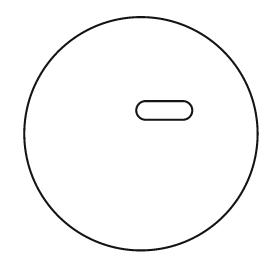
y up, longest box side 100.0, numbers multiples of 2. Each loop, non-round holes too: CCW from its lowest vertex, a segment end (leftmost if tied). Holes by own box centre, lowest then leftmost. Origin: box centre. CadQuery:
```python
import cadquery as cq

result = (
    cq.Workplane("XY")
    .moveTo(0.0, 0.0)
    .circle(50.0)
    .moveTo(2.0, 6.0)
    .lineTo(18.0, 6.0)
    .threePointArc((22.0, 10.0), (18.0, 14.0))
    .lineTo(2.0, 14.0)
    .threePointArc((-2.0, 10.0), (2.0, 6.0))
    .close()
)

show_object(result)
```